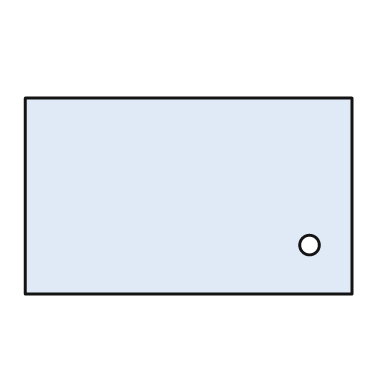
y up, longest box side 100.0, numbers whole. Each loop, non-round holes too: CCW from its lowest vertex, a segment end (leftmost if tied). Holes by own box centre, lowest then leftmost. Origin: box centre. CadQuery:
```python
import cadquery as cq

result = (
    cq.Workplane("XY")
    .moveTo(-50.0, -30.0)
    .lineTo(50.0, -30.0)
    .lineTo(50.0, 30.0)
    .lineTo(-50.0, 30.0)
    .close()
    .moveTo(37.0, -15.0)
    .circle(3.0)
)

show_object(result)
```